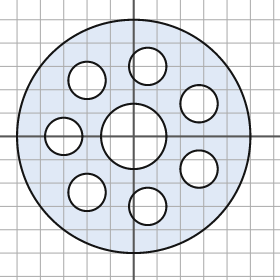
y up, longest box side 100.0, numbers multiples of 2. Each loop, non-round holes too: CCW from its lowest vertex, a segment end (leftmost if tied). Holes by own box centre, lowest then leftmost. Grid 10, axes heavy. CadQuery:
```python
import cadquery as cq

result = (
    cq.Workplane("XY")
    .moveTo(0.0, 0.0)
    .circle(50.0)
    .moveTo(6.0, -30.0)
    .circle(8.0)
    .moveTo(-20.0, -24.0)
    .circle(8.0)
    .moveTo(28.0, -14.0)
    .circle(8.0)
    .moveTo(-30.0, 0.0)
    .circle(8.0)
    .moveTo(0.0, 0.0)
    .circle(14.0)
    .moveTo(28.0, 14.0)
    .circle(8.0)
    .moveTo(-20.0, 24.0)
    .circle(8.0)
    .moveTo(6.0, 30.0)
    .circle(8.0)
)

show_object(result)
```